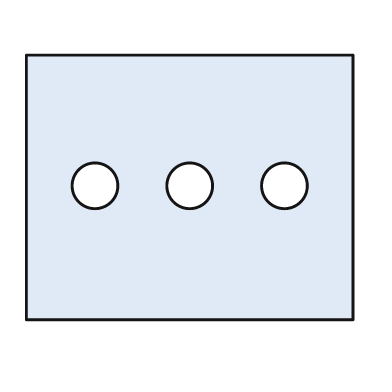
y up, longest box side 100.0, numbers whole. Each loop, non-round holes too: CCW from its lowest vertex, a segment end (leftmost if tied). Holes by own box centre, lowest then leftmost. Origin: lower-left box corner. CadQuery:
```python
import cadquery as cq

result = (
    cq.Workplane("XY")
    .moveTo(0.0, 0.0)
    .lineTo(100.0, 0.0)
    .lineTo(100.0, 81.0)
    .lineTo(0.0, 81.0)
    .close()
    .moveTo(21.0, 41.0)
    .circle(7.0)
    .moveTo(50.0, 41.0)
    .circle(7.0)
    .moveTo(79.0, 41.0)
    .circle(7.0)
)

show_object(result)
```